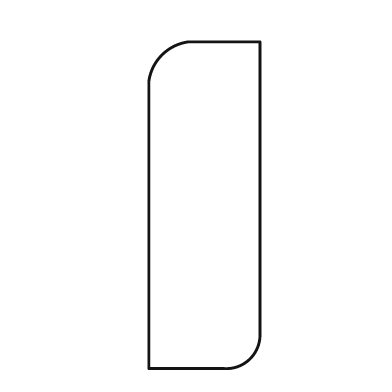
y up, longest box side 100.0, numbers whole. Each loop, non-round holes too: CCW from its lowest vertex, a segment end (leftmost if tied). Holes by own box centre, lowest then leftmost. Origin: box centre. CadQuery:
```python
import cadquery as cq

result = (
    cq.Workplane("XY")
    .moveTo(-17.0, -50.0)
    .lineTo(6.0, -50.0)
    .threePointArc((14.0, -47.0), (17.0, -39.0))
    .lineTo(17.0, 50.0)
    .lineTo(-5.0, 50.0)
    .threePointArc((-13.0, 46.0), (-17.0, 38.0))
    .close()
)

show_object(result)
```